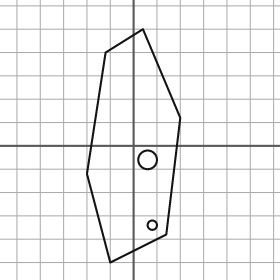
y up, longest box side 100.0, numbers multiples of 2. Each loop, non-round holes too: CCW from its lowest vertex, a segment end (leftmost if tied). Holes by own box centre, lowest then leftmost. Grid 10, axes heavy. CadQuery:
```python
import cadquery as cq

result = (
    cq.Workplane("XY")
    .moveTo(-10.0, -50.0)
    .lineTo(14.0, -38.0)
    .lineTo(20.0, 12.0)
    .lineTo(4.0, 50.0)
    .lineTo(-12.0, 40.0)
    .lineTo(-20.0, -12.0)
    .close()
    .moveTo(8.0, -34.0)
    .circle(2.0)
    .moveTo(6.0, -6.0)
    .circle(4.0)
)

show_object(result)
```